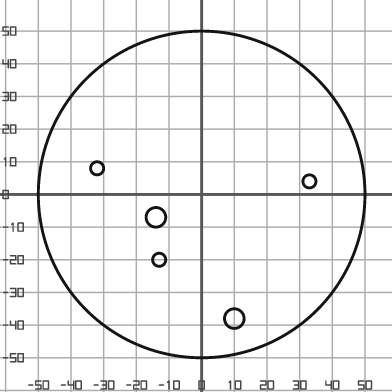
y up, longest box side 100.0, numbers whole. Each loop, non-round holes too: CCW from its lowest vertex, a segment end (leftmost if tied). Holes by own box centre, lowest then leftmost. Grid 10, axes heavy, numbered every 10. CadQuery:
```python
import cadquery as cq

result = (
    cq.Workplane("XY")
    .moveTo(0.0, 0.0)
    .circle(50.0)
    .moveTo(10.0, -38.0)
    .circle(3.0)
    .moveTo(-13.0, -20.0)
    .circle(2.0)
    .moveTo(-14.0, -7.0)
    .circle(3.0)
    .moveTo(33.0, 4.0)
    .circle(2.0)
    .moveTo(-32.0, 8.0)
    .circle(2.0)
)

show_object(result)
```